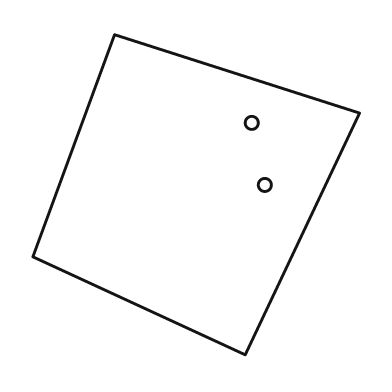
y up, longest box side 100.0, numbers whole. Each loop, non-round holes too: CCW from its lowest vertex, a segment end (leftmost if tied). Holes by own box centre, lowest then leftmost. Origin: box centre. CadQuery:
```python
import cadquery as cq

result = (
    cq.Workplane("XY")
    .moveTo(15.0, -49.0)
    .lineTo(50.0, 25.0)
    .lineTo(-25.0, 49.0)
    .lineTo(-50.0, -19.0)
    .close()
    .moveTo(21.0, 3.0)
    .circle(2.0)
    .moveTo(17.0, 22.0)
    .circle(2.0)
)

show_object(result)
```